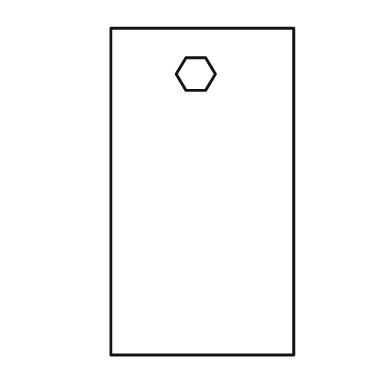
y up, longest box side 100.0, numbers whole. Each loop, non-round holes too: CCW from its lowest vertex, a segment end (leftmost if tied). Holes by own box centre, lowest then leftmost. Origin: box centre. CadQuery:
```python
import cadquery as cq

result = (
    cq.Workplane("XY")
    .moveTo(-28.0, -50.0)
    .lineTo(28.0, -50.0)
    .lineTo(28.0, 50.0)
    .lineTo(-28.0, 50.0)
    .close()
    .moveTo(-5.0, 31.0)
    .lineTo(1.0, 31.0)
    .lineTo(4.0, 36.0)
    .lineTo(1.0, 41.0)
    .lineTo(-5.0, 41.0)
    .lineTo(-8.0, 36.0)
    .close()
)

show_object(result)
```